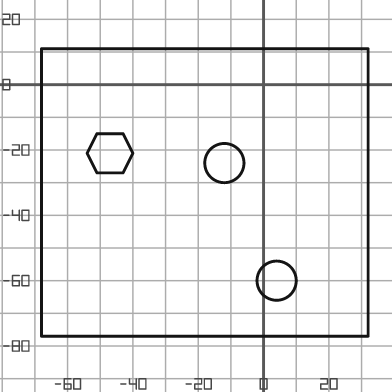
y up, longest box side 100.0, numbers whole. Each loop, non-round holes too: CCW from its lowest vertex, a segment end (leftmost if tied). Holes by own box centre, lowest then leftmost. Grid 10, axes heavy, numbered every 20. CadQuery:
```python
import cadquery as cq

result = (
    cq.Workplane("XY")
    .moveTo(-68.0, -77.0)
    .lineTo(32.0, -77.0)
    .lineTo(32.0, 11.0)
    .lineTo(-68.0, 11.0)
    .close()
    .moveTo(4.0, -60.0)
    .circle(6.0)
    .moveTo(-12.0, -24.0)
    .circle(6.0)
    .moveTo(-51.0, -27.0)
    .lineTo(-43.0, -27.0)
    .lineTo(-40.0, -21.0)
    .lineTo(-43.0, -15.0)
    .lineTo(-51.0, -15.0)
    .lineTo(-54.0, -21.0)
    .close()
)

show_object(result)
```